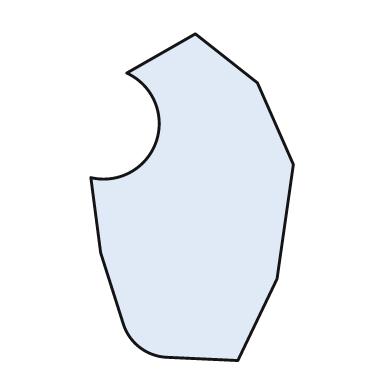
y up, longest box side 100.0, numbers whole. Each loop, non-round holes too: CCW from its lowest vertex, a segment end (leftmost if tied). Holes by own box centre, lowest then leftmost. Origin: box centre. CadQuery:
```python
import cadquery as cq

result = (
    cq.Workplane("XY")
    .moveTo(14.0, -50.0)
    .lineTo(26.0, -25.0)
    .lineTo(31.0, 10.0)
    .lineTo(20.0, 35.0)
    .lineTo(1.0, 50.0)
    .lineTo(-20.0, 38.0)
    .threePointArc((-11.0, 17.0), (-31.0, 6.0))
    .lineTo(-28.0, -17.0)
    .lineTo(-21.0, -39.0)
    .threePointArc((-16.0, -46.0), (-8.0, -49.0))
    .close()
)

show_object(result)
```